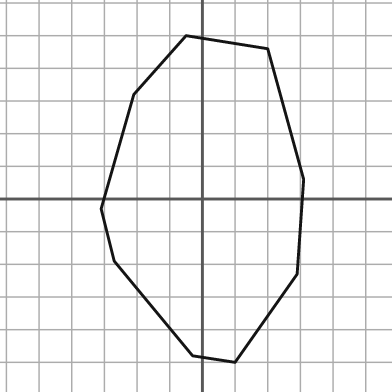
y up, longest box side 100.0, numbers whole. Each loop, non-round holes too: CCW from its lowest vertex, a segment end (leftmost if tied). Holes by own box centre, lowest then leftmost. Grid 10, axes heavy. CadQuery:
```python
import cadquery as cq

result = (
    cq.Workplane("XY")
    .moveTo(10.0, -50.0)
    .lineTo(29.0, -23.0)
    .lineTo(31.0, 6.0)
    .lineTo(20.0, 46.0)
    .lineTo(-5.0, 50.0)
    .lineTo(-21.0, 32.0)
    .lineTo(-31.0, -3.0)
    .lineTo(-27.0, -19.0)
    .lineTo(-3.0, -48.0)
    .close()
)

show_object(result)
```